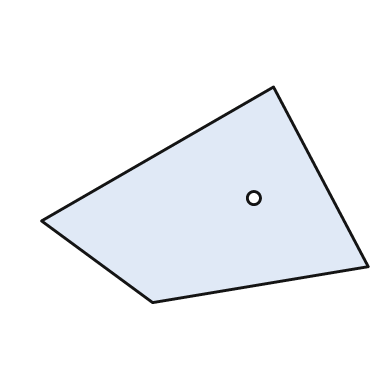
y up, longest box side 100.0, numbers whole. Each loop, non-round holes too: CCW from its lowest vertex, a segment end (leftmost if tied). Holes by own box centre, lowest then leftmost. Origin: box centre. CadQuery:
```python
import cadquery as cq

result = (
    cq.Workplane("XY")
    .moveTo(-16.0, -33.0)
    .lineTo(50.0, -22.0)
    .lineTo(21.0, 33.0)
    .lineTo(-50.0, -8.0)
    .close()
    .moveTo(15.0, -1.0)
    .circle(2.0)
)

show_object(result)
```